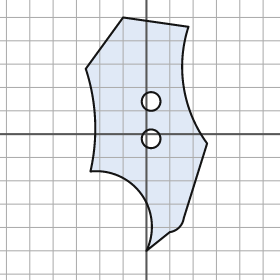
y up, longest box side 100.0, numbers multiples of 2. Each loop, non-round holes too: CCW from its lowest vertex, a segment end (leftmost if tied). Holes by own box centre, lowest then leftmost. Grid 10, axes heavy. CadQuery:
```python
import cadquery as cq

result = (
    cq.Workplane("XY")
    .moveTo(0.0, -50.0)
    .lineTo(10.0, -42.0)
    .threePointArc((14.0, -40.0), (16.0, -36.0))
    .lineTo(26.0, -4.0)
    .threePointArc((16.0, 20.0), (18.0, 46.0))
    .lineTo(-10.0, 50.0)
    .lineTo(-26.0, 28.0)
    .threePointArc((-22.0, 6.0), (-24.0, -16.0))
    .threePointArc((-2.0, -26.0), (0.0, -50.0))
    .close()
    .moveTo(2.0, -2.0)
    .circle(4.0)
    .moveTo(2.0, 14.0)
    .circle(4.0)
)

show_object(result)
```